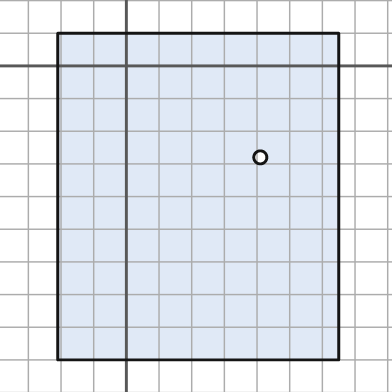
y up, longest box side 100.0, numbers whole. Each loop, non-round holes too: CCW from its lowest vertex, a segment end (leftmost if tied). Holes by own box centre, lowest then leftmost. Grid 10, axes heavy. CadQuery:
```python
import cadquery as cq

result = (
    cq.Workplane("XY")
    .moveTo(-21.0, -90.0)
    .lineTo(65.0, -90.0)
    .lineTo(65.0, 10.0)
    .lineTo(-21.0, 10.0)
    .close()
    .moveTo(41.0, -28.0)
    .circle(2.0)
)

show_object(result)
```